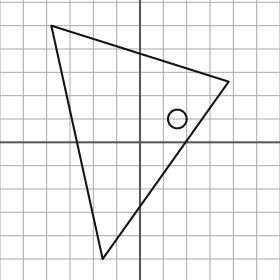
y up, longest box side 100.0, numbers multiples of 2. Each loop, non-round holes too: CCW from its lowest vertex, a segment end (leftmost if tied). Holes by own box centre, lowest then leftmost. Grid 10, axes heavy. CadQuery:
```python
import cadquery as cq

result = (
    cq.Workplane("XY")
    .moveTo(-16.0, -50.0)
    .lineTo(38.0, 26.0)
    .lineTo(-38.0, 50.0)
    .close()
    .moveTo(16.0, 10.0)
    .circle(4.0)
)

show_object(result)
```